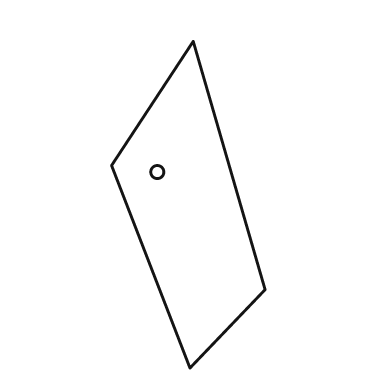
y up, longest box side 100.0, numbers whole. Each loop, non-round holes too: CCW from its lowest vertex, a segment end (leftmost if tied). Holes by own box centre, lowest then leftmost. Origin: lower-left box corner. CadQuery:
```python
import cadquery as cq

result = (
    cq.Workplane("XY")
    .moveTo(24.0, 0.0)
    .lineTo(47.0, 24.0)
    .lineTo(25.0, 100.0)
    .lineTo(0.0, 62.0)
    .close()
    .moveTo(14.0, 60.0)
    .circle(2.0)
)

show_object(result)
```